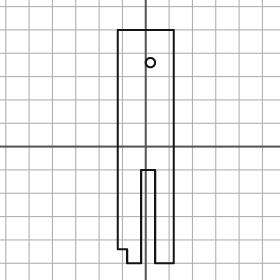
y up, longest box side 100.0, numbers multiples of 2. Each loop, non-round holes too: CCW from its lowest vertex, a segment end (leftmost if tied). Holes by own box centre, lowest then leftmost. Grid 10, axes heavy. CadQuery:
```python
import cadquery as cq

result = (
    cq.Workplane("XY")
    .moveTo(-8.0, -50.0)
    .lineTo(-2.0, -50.0)
    .lineTo(-2.0, -10.0)
    .lineTo(4.0, -10.0)
    .lineTo(4.0, -50.0)
    .lineTo(12.0, -50.0)
    .lineTo(12.0, 50.0)
    .lineTo(-12.0, 50.0)
    .lineTo(-12.0, -44.0)
    .lineTo(-8.0, -44.0)
    .close()
    .moveTo(2.0, 36.0)
    .circle(2.0)
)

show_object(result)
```